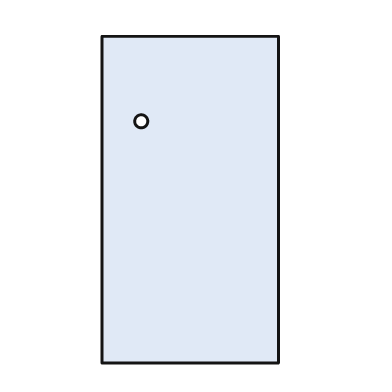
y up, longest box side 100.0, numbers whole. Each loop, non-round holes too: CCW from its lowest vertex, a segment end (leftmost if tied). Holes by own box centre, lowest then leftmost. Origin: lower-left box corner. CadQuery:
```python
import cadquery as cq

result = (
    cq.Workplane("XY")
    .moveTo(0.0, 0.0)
    .lineTo(54.0, 0.0)
    .lineTo(54.0, 100.0)
    .lineTo(0.0, 100.0)
    .close()
    .moveTo(12.0, 74.0)
    .circle(2.0)
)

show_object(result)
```